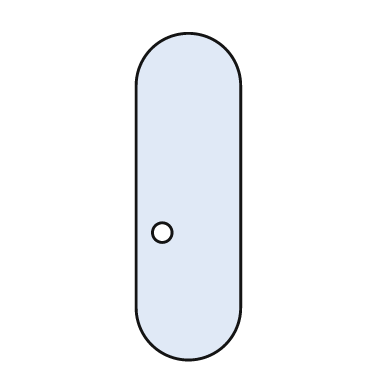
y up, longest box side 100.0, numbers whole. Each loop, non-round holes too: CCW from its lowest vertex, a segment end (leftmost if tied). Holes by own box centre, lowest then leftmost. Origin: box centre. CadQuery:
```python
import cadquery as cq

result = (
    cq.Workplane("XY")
    .moveTo(-16.0, -34.0)
    .threePointArc((0.0, -50.0), (16.0, -34.0))
    .lineTo(16.0, 34.0)
    .threePointArc((0.0, 50.0), (-16.0, 34.0))
    .close()
    .moveTo(-8.0, -11.0)
    .circle(3.0)
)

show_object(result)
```